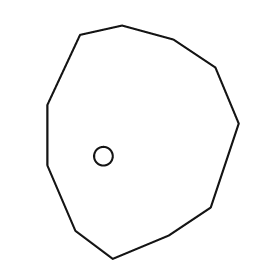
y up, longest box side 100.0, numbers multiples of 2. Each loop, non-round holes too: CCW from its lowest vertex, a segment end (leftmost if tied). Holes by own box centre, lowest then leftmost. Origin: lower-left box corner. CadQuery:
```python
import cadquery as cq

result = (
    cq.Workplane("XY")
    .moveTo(28.0, 0.0)
    .lineTo(52.0, 10.0)
    .lineTo(70.0, 22.0)
    .lineTo(82.0, 58.0)
    .lineTo(72.0, 82.0)
    .lineTo(54.0, 94.0)
    .lineTo(32.0, 100.0)
    .lineTo(14.0, 96.0)
    .lineTo(0.0, 66.0)
    .lineTo(0.0, 40.0)
    .lineTo(12.0, 12.0)
    .close()
    .moveTo(24.0, 44.0)
    .circle(4.0)
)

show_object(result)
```